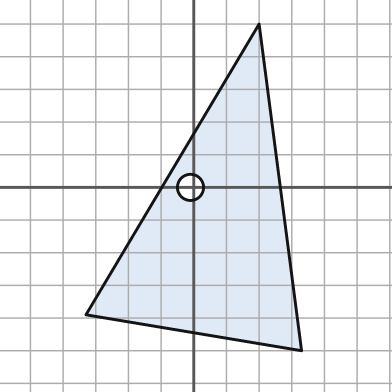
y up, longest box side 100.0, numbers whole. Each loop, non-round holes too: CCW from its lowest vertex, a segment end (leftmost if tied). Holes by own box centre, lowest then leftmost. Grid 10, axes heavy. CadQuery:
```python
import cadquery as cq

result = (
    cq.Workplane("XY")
    .moveTo(33.0, -50.0)
    .lineTo(20.0, 50.0)
    .lineTo(-33.0, -39.0)
    .close()
    .moveTo(-1.0, 0.0)
    .circle(4.0)
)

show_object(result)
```